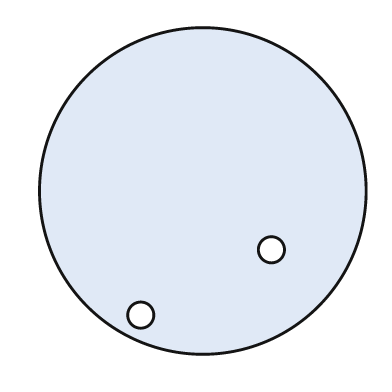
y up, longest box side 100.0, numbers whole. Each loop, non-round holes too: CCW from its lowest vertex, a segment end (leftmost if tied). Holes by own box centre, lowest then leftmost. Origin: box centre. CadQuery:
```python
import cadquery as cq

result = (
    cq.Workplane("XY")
    .moveTo(0.0, 0.0)
    .circle(50.0)
    .moveTo(-19.0, -38.0)
    .circle(4.0)
    .moveTo(21.0, -18.0)
    .circle(4.0)
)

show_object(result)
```